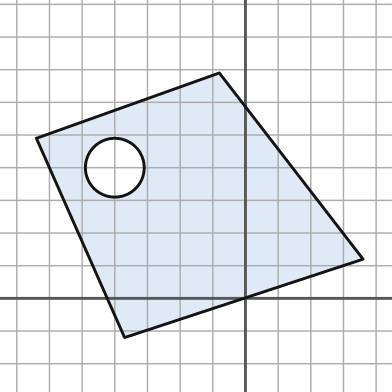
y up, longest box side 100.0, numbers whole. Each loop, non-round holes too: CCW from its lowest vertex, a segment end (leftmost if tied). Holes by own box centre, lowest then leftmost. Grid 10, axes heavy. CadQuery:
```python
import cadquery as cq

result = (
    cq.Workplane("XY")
    .moveTo(-37.0, -12.0)
    .lineTo(36.0, 12.0)
    .lineTo(-8.0, 69.0)
    .lineTo(-64.0, 49.0)
    .close()
    .moveTo(-40.0, 40.0)
    .circle(9.0)
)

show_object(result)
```